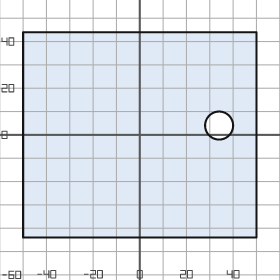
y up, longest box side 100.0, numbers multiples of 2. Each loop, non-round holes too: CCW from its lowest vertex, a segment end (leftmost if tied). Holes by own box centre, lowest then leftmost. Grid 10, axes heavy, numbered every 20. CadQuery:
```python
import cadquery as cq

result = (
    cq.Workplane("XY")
    .moveTo(-50.0, -44.0)
    .lineTo(50.0, -44.0)
    .lineTo(50.0, 44.0)
    .lineTo(-50.0, 44.0)
    .close()
    .moveTo(34.0, 4.0)
    .circle(6.0)
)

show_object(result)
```